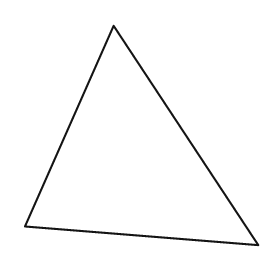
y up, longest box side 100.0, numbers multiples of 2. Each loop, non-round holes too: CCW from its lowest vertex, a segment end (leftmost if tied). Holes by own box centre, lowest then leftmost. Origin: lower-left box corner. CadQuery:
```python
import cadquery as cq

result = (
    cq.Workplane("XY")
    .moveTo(100.0, 0.0)
    .lineTo(38.0, 94.0)
    .lineTo(0.0, 8.0)
    .close()
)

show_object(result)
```